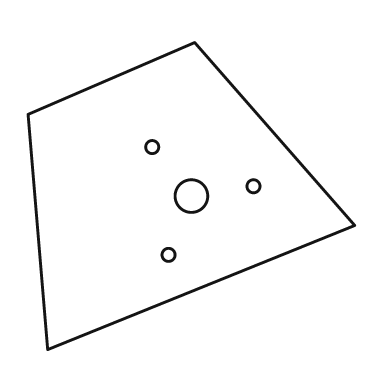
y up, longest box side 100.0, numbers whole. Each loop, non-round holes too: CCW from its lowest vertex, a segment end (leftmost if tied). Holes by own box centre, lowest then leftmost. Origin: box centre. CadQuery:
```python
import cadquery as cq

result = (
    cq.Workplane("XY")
    .moveTo(-44.0, -47.0)
    .lineTo(50.0, -9.0)
    .lineTo(1.0, 47.0)
    .lineTo(-50.0, 25.0)
    .close()
    .moveTo(-7.0, -18.0)
    .circle(2.0)
    .moveTo(0.0, 0.0)
    .circle(5.0)
    .moveTo(19.0, 3.0)
    .circle(2.0)
    .moveTo(-12.0, 15.0)
    .circle(2.0)
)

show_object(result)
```